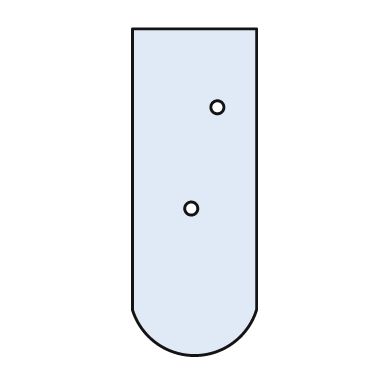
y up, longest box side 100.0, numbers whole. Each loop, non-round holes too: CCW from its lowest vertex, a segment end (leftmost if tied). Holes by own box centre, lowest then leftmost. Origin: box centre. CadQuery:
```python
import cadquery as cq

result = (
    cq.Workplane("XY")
    .moveTo(-19.0, -36.0)
    .threePointArc((0.0, -50.0), (19.0, -36.0))
    .lineTo(19.0, 50.0)
    .lineTo(-19.0, 50.0)
    .close()
    .moveTo(-1.0, -5.0)
    .circle(2.0)
    .moveTo(7.0, 26.0)
    .circle(2.0)
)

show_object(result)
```